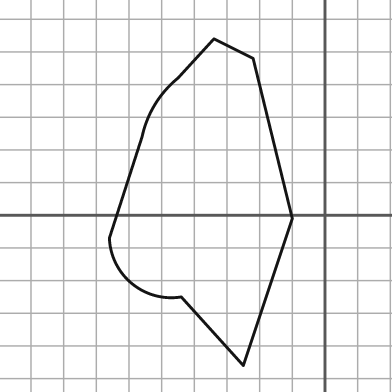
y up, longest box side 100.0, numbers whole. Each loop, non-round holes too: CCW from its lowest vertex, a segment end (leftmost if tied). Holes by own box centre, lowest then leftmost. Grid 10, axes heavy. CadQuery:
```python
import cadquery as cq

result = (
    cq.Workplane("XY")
    .moveTo(-25.0, -46.0)
    .lineTo(-10.0, -1.0)
    .lineTo(-22.0, 48.0)
    .lineTo(-34.0, 54.0)
    .lineTo(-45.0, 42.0)
    .threePointArc((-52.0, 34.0), (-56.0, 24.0))
    .lineTo(-66.0, -7.0)
    .threePointArc((-59.0, -21.0), (-44.0, -25.0))
    .close()
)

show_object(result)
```